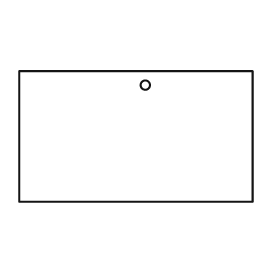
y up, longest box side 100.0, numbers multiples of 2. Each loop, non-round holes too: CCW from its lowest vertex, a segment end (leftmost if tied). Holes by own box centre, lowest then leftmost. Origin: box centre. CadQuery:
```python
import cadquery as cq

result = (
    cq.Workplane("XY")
    .moveTo(-50.0, -28.0)
    .lineTo(50.0, -28.0)
    .lineTo(50.0, 28.0)
    .lineTo(-50.0, 28.0)
    .close()
    .moveTo(4.0, 22.0)
    .circle(2.0)
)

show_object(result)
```